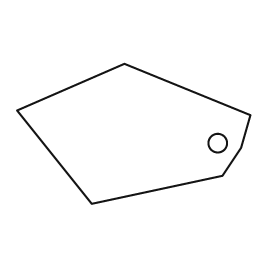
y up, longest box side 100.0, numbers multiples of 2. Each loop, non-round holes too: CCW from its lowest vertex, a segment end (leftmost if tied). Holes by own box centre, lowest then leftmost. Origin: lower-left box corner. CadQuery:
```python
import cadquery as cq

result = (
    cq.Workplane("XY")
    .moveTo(32.0, 0.0)
    .lineTo(88.0, 12.0)
    .lineTo(96.0, 24.0)
    .lineTo(100.0, 38.0)
    .lineTo(46.0, 60.0)
    .lineTo(0.0, 40.0)
    .close()
    .moveTo(86.0, 26.0)
    .circle(4.0)
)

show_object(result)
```